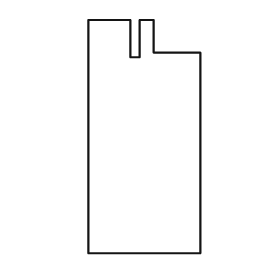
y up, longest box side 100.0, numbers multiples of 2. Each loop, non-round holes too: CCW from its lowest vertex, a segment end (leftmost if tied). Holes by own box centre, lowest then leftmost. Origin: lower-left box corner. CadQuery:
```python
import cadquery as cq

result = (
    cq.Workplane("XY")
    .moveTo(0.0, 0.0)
    .lineTo(48.0, 0.0)
    .lineTo(48.0, 86.0)
    .lineTo(28.0, 86.0)
    .lineTo(28.0, 100.0)
    .lineTo(22.0, 100.0)
    .lineTo(22.0, 84.0)
    .lineTo(18.0, 84.0)
    .lineTo(18.0, 100.0)
    .lineTo(0.0, 100.0)
    .close()
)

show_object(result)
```